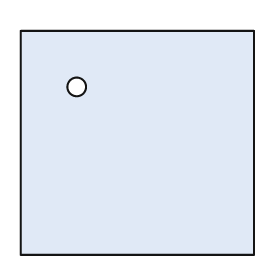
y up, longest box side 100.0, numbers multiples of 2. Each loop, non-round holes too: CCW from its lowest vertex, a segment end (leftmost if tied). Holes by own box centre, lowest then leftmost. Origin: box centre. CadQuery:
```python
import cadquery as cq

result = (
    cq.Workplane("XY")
    .moveTo(-50.0, -48.0)
    .lineTo(50.0, -48.0)
    .lineTo(50.0, 48.0)
    .lineTo(-50.0, 48.0)
    .close()
    .moveTo(-26.0, 24.0)
    .circle(4.0)
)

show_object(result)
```